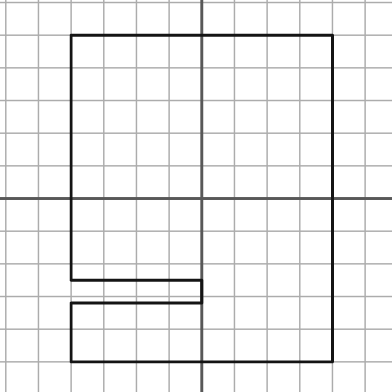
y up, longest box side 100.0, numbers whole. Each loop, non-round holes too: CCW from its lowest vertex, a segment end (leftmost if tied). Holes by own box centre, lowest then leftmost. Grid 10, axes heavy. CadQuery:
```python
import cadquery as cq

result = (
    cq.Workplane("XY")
    .moveTo(-40.0, -50.0)
    .lineTo(40.0, -50.0)
    .lineTo(40.0, 50.0)
    .lineTo(-40.0, 50.0)
    .lineTo(-40.0, -25.0)
    .lineTo(0.0, -25.0)
    .lineTo(0.0, -32.0)
    .lineTo(-40.0, -32.0)
    .close()
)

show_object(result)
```